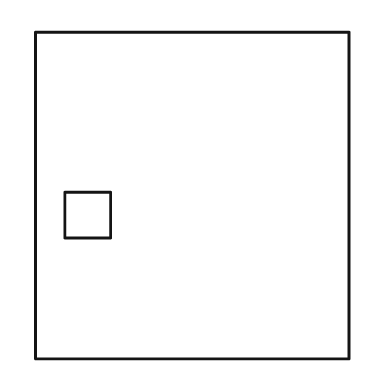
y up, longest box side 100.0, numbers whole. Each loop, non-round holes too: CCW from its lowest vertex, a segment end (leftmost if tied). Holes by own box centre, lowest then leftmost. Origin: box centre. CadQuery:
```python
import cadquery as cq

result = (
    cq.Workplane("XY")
    .moveTo(-48.0, -50.0)
    .lineTo(48.0, -50.0)
    .lineTo(48.0, 50.0)
    .lineTo(-48.0, 50.0)
    .close()
    .moveTo(-39.0, -13.0)
    .lineTo(-25.0, -13.0)
    .lineTo(-25.0, 1.0)
    .lineTo(-39.0, 1.0)
    .close()
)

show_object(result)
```